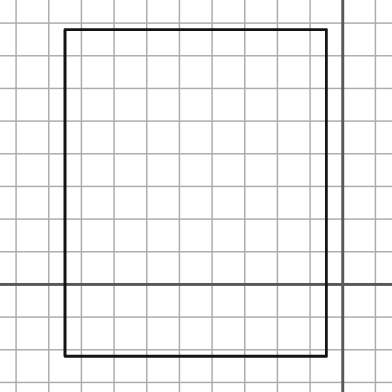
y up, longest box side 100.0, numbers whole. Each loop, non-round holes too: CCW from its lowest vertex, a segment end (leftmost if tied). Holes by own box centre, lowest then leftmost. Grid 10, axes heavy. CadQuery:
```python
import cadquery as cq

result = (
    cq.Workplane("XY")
    .moveTo(-85.0, -22.0)
    .lineTo(-5.0, -22.0)
    .lineTo(-5.0, 78.0)
    .lineTo(-85.0, 78.0)
    .close()
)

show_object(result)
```